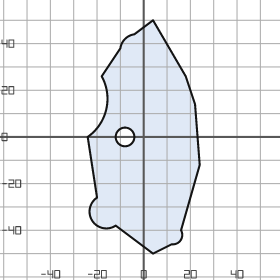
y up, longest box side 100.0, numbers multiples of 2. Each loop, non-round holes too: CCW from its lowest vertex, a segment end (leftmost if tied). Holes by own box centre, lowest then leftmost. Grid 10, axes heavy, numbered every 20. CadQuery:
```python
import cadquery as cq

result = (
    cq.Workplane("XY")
    .moveTo(4.0, -50.0)
    .lineTo(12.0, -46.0)
    .threePointArc((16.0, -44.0), (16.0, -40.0))
    .lineTo(24.0, -12.0)
    .lineTo(22.0, 14.0)
    .lineTo(18.0, 26.0)
    .lineTo(4.0, 50.0)
    .lineTo(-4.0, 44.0)
    .threePointArc((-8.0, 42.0), (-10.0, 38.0))
    .lineTo(-18.0, 26.0)
    .threePointArc((-16.0, 12.0), (-24.0, 0.0))
    .lineTo(-20.0, -26.0)
    .threePointArc((-22.0, -36.0), (-12.0, -38.0))
    .close()
    .moveTo(-8.0, 0.0)
    .circle(4.0)
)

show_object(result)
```